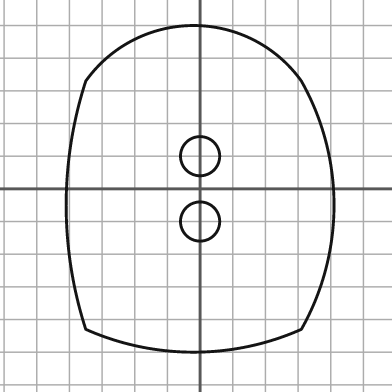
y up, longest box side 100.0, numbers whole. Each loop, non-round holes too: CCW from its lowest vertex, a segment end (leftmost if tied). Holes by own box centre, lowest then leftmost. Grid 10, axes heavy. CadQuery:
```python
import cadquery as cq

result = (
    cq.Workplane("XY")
    .moveTo(-35.0, -43.0)
    .threePointArc((-2.0, -50.0), (31.0, -43.0))
    .threePointArc((41.0, -5.0), (31.0, 33.0))
    .threePointArc((-2.0, 50.0), (-35.0, 33.0))
    .threePointArc((-41.0, -5.0), (-35.0, -43.0))
    .close()
    .moveTo(0.0, -10.0)
    .circle(6.0)
    .moveTo(0.0, 10.0)
    .circle(6.0)
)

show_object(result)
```